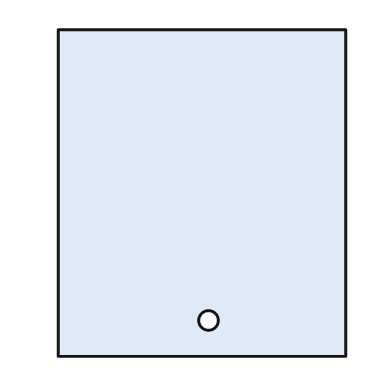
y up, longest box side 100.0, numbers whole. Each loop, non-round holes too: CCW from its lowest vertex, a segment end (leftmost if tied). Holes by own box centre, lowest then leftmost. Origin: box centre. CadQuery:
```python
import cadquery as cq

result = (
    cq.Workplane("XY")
    .moveTo(-44.0, -50.0)
    .lineTo(44.0, -50.0)
    .lineTo(44.0, 50.0)
    .lineTo(-44.0, 50.0)
    .close()
    .moveTo(2.0, -39.0)
    .circle(3.0)
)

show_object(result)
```